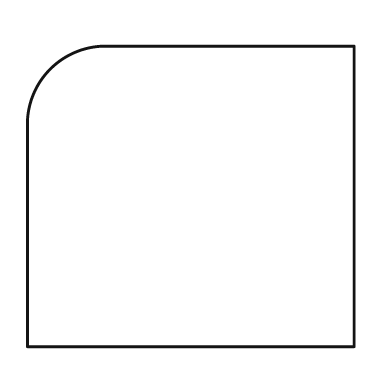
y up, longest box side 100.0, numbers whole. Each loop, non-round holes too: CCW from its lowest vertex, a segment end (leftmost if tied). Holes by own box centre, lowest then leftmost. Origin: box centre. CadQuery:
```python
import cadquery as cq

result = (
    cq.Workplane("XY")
    .moveTo(-50.0, -46.0)
    .lineTo(50.0, -46.0)
    .lineTo(50.0, 46.0)
    .lineTo(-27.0, 46.0)
    .threePointArc((-43.0, 39.0), (-50.0, 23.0))
    .close()
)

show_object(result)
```